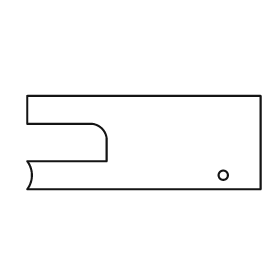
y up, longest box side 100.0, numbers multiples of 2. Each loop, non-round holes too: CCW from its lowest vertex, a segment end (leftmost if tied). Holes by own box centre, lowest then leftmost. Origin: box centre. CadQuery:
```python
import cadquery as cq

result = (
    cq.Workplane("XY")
    .moveTo(-50.0, -20.0)
    .lineTo(50.0, -20.0)
    .lineTo(50.0, 20.0)
    .lineTo(-50.0, 20.0)
    .lineTo(-50.0, 8.0)
    .lineTo(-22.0, 8.0)
    .threePointArc((-18.0, 6.0), (-16.0, 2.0))
    .lineTo(-16.0, -8.0)
    .lineTo(-50.0, -8.0)
    .threePointArc((-48.0, -14.0), (-50.0, -20.0))
    .close()
    .moveTo(34.0, -14.0)
    .circle(2.0)
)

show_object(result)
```